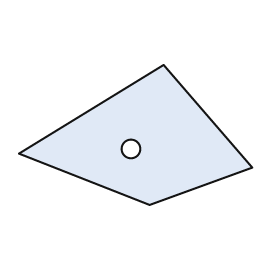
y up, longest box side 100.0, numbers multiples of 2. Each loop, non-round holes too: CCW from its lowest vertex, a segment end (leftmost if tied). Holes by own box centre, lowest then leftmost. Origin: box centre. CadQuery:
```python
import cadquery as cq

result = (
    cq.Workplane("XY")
    .moveTo(6.0, -30.0)
    .lineTo(50.0, -14.0)
    .lineTo(12.0, 30.0)
    .lineTo(-50.0, -8.0)
    .close()
    .moveTo(-2.0, -6.0)
    .circle(4.0)
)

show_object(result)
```